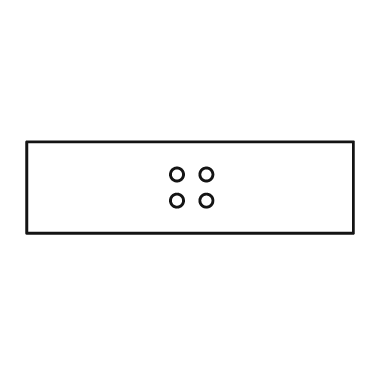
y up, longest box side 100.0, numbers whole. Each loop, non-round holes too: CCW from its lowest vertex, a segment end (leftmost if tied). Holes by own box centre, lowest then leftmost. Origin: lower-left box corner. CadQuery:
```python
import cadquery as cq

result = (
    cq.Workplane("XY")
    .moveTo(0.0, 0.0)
    .lineTo(100.0, 0.0)
    .lineTo(100.0, 28.0)
    .lineTo(0.0, 28.0)
    .close()
    .moveTo(46.0, 10.0)
    .circle(2.0)
    .moveTo(55.0, 10.0)
    .circle(2.0)
    .moveTo(46.0, 18.0)
    .circle(2.0)
    .moveTo(55.0, 18.0)
    .circle(2.0)
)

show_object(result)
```